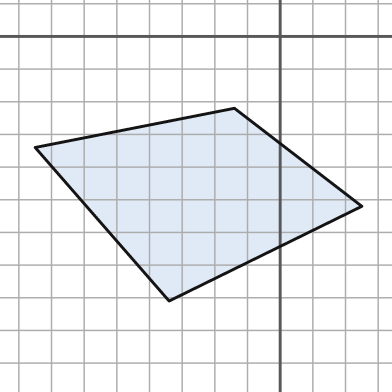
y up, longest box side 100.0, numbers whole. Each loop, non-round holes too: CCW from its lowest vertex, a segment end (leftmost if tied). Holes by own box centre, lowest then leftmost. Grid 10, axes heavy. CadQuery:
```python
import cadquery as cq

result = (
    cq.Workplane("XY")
    .moveTo(-34.0, -81.0)
    .lineTo(25.0, -52.0)
    .lineTo(-14.0, -22.0)
    .lineTo(-75.0, -34.0)
    .close()
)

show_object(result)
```